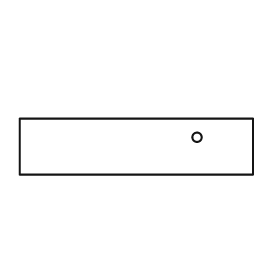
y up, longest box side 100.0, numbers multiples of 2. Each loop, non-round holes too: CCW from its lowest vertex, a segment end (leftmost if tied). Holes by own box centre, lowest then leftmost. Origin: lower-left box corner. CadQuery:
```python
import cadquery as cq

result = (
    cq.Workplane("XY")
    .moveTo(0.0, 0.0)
    .lineTo(100.0, 0.0)
    .lineTo(100.0, 24.0)
    .lineTo(0.0, 24.0)
    .close()
    .moveTo(76.0, 16.0)
    .circle(2.0)
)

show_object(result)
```